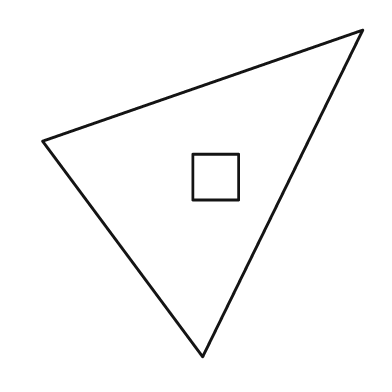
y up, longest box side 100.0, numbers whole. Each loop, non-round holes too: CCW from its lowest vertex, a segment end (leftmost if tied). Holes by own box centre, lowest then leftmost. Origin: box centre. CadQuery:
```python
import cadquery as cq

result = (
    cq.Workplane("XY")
    .moveTo(0.0, -50.0)
    .lineTo(49.0, 50.0)
    .lineTo(-49.0, 16.0)
    .close()
    .moveTo(-3.0, -2.0)
    .lineTo(11.0, -2.0)
    .lineTo(11.0, 12.0)
    .lineTo(-3.0, 12.0)
    .close()
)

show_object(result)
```